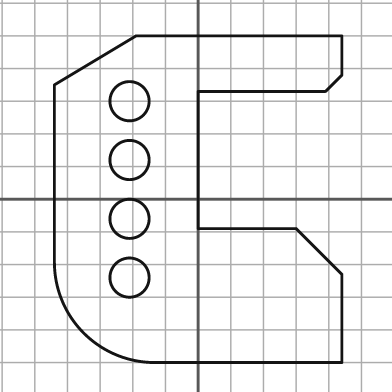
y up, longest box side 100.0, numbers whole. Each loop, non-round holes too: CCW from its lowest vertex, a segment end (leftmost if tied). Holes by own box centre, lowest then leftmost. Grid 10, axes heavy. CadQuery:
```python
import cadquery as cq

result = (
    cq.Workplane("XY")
    .moveTo(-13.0, -50.0)
    .lineTo(44.0, -50.0)
    .lineTo(44.0, -23.0)
    .lineTo(30.0, -9.0)
    .lineTo(0.0, -9.0)
    .lineTo(0.0, 33.0)
    .lineTo(39.0, 33.0)
    .lineTo(44.0, 38.0)
    .lineTo(44.0, 50.0)
    .lineTo(-19.0, 50.0)
    .lineTo(-44.0, 35.0)
    .lineTo(-44.0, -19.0)
    .threePointArc((-35.0, -41.0), (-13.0, -50.0))
    .close()
    .moveTo(-21.0, -24.0)
    .circle(6.0)
    .moveTo(-21.0, -6.0)
    .circle(6.0)
    .moveTo(-21.0, 12.0)
    .circle(6.0)
    .moveTo(-21.0, 30.0)
    .circle(6.0)
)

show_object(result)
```